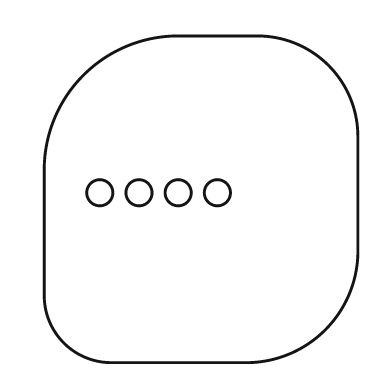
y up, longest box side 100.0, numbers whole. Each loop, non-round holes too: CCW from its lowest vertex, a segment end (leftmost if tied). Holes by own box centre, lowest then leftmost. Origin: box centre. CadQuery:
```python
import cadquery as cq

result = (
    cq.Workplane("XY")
    .moveTo(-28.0, -50.0)
    .lineTo(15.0, -50.0)
    .threePointArc((38.0, -40.0), (48.0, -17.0))
    .lineTo(48.0, 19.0)
    .threePointArc((39.0, 41.0), (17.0, 50.0))
    .lineTo(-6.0, 50.0)
    .threePointArc((-36.0, 38.0), (-48.0, 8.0))
    .lineTo(-48.0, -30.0)
    .threePointArc((-42.0, -44.0), (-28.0, -50.0))
    .close()
    .moveTo(-31.0, 2.0)
    .circle(4.0)
    .moveTo(-19.0, 2.0)
    .circle(4.0)
    .moveTo(-7.0, 2.0)
    .circle(4.0)
    .moveTo(5.0, 2.0)
    .circle(4.0)
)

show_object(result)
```